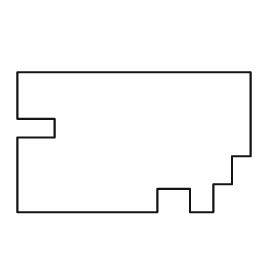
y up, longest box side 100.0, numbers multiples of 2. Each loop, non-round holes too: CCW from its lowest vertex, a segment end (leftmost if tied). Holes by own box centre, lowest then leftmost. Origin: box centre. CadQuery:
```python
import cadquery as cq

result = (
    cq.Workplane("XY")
    .moveTo(-50.0, -30.0)
    .lineTo(10.0, -30.0)
    .lineTo(10.0, -20.0)
    .lineTo(24.0, -20.0)
    .lineTo(24.0, -30.0)
    .lineTo(34.0, -30.0)
    .lineTo(34.0, -18.0)
    .lineTo(42.0, -18.0)
    .lineTo(42.0, -6.0)
    .lineTo(50.0, -6.0)
    .lineTo(50.0, 30.0)
    .lineTo(-50.0, 30.0)
    .lineTo(-50.0, 10.0)
    .lineTo(-34.0, 10.0)
    .lineTo(-34.0, 2.0)
    .lineTo(-50.0, 2.0)
    .close()
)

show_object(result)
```